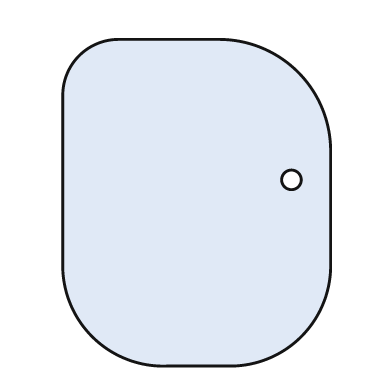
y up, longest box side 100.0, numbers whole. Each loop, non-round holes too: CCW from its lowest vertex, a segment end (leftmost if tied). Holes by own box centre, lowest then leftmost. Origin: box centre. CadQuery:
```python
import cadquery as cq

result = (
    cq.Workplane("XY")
    .moveTo(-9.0, -50.0)
    .lineTo(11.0, -50.0)
    .threePointArc((32.0, -41.0), (41.0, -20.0))
    .lineTo(41.0, 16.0)
    .threePointArc((31.0, 40.0), (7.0, 50.0))
    .lineTo(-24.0, 50.0)
    .threePointArc((-36.0, 45.0), (-41.0, 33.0))
    .lineTo(-41.0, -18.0)
    .threePointArc((-32.0, -41.0), (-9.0, -50.0))
    .close()
    .moveTo(29.0, 7.0)
    .circle(3.0)
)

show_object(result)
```